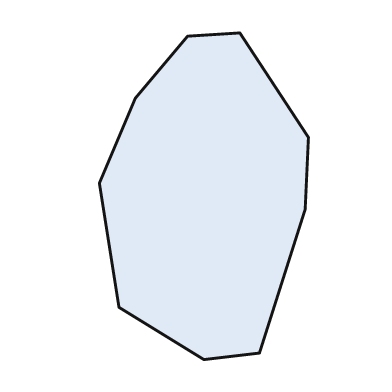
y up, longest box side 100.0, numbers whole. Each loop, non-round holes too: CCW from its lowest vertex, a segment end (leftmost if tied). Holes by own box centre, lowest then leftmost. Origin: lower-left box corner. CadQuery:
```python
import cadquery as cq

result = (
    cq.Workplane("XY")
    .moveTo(32.0, 0.0)
    .lineTo(49.0, 2.0)
    .lineTo(63.0, 46.0)
    .lineTo(64.0, 68.0)
    .lineTo(43.0, 100.0)
    .lineTo(27.0, 99.0)
    .lineTo(11.0, 80.0)
    .lineTo(0.0, 54.0)
    .lineTo(6.0, 16.0)
    .close()
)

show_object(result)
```